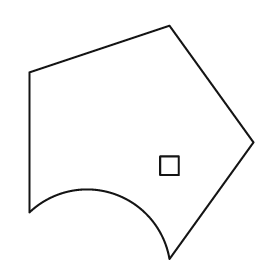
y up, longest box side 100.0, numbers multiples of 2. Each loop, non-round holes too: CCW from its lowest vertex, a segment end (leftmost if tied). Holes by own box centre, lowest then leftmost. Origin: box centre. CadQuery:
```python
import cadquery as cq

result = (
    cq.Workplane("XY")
    .moveTo(12.0, -50.0)
    .lineTo(48.0, 0.0)
    .lineTo(12.0, 50.0)
    .lineTo(-48.0, 30.0)
    .lineTo(-48.0, -30.0)
    .threePointArc((-12.0, -22.0), (12.0, -50.0))
    .close()
    .moveTo(8.0, -14.0)
    .lineTo(16.0, -14.0)
    .lineTo(16.0, -6.0)
    .lineTo(8.0, -6.0)
    .close()
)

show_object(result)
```